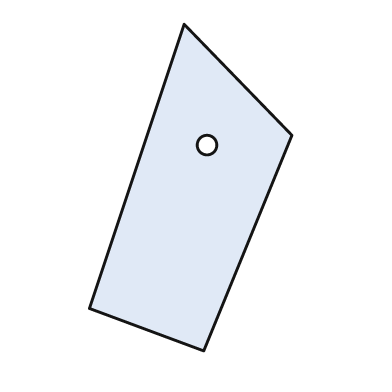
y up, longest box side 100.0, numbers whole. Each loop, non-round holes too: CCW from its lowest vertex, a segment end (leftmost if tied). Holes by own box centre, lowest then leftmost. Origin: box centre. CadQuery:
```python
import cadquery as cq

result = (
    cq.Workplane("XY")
    .moveTo(4.0, -50.0)
    .lineTo(31.0, 16.0)
    .lineTo(-2.0, 50.0)
    .lineTo(-31.0, -37.0)
    .close()
    .moveTo(5.0, 13.0)
    .circle(3.0)
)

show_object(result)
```